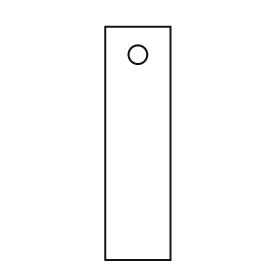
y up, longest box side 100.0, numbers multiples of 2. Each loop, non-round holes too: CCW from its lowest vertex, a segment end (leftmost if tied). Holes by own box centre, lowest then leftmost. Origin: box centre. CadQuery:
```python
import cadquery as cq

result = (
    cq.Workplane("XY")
    .moveTo(-14.0, -50.0)
    .lineTo(14.0, -50.0)
    .lineTo(14.0, 50.0)
    .lineTo(-14.0, 50.0)
    .close()
    .moveTo(0.0, 38.0)
    .circle(4.0)
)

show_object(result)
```